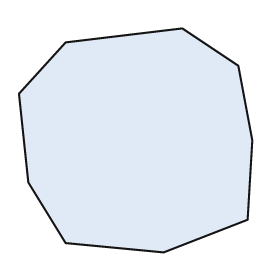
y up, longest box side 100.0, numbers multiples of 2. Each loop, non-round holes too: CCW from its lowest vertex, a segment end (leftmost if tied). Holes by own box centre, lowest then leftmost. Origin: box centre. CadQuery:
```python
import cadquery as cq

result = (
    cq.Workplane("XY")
    .moveTo(12.0, -48.0)
    .lineTo(48.0, -34.0)
    .lineTo(50.0, 0.0)
    .lineTo(44.0, 32.0)
    .lineTo(20.0, 48.0)
    .lineTo(-30.0, 42.0)
    .lineTo(-50.0, 20.0)
    .lineTo(-46.0, -18.0)
    .lineTo(-30.0, -44.0)
    .close()
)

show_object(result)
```